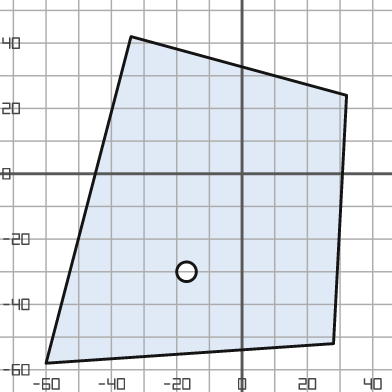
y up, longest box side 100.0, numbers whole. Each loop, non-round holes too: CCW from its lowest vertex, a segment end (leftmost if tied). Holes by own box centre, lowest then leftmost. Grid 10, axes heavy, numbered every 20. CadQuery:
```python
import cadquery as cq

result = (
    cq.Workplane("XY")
    .moveTo(-60.0, -58.0)
    .lineTo(28.0, -52.0)
    .lineTo(32.0, 24.0)
    .lineTo(-34.0, 42.0)
    .close()
    .moveTo(-17.0, -30.0)
    .circle(3.0)
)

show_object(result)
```